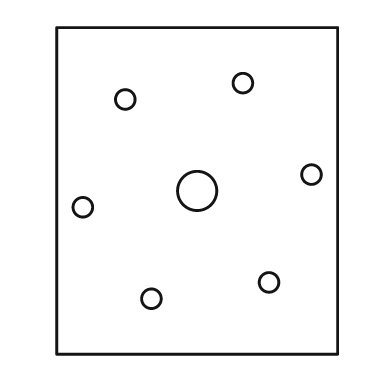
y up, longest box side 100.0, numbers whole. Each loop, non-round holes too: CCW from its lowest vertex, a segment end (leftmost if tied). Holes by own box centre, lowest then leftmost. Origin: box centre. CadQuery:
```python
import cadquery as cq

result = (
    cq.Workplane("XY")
    .moveTo(-43.0, -50.0)
    .lineTo(43.0, -50.0)
    .lineTo(43.0, 50.0)
    .lineTo(-43.0, 50.0)
    .close()
    .moveTo(-14.0, -33.0)
    .circle(3.0)
    .moveTo(22.0, -28.0)
    .circle(3.0)
    .moveTo(-35.0, -5.0)
    .circle(3.0)
    .moveTo(0.0, 0.0)
    .circle(6.0)
    .moveTo(35.0, 5.0)
    .circle(3.0)
    .moveTo(-22.0, 28.0)
    .circle(3.0)
    .moveTo(14.0, 33.0)
    .circle(3.0)
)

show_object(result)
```